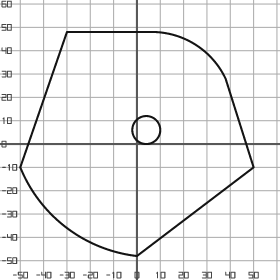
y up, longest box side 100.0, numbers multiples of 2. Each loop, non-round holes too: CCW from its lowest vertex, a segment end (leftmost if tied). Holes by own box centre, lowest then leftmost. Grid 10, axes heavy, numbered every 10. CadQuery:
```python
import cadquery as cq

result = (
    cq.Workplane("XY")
    .moveTo(0.0, -48.0)
    .lineTo(50.0, -10.0)
    .lineTo(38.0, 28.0)
    .threePointArc((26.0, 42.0), (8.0, 48.0))
    .lineTo(-30.0, 48.0)
    .lineTo(-50.0, -10.0)
    .threePointArc((-30.0, -36.0), (0.0, -48.0))
    .close()
    .moveTo(4.0, 6.0)
    .circle(6.0)
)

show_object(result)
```